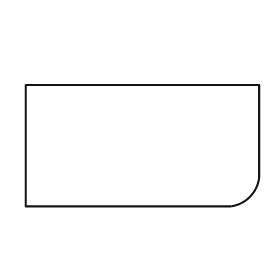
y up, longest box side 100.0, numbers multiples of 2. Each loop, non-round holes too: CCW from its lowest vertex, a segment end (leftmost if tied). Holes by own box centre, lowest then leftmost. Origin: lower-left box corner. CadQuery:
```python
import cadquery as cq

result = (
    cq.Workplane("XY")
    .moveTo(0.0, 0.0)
    .lineTo(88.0, 0.0)
    .threePointArc((96.0, 4.0), (100.0, 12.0))
    .lineTo(100.0, 52.0)
    .lineTo(0.0, 52.0)
    .close()
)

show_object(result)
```